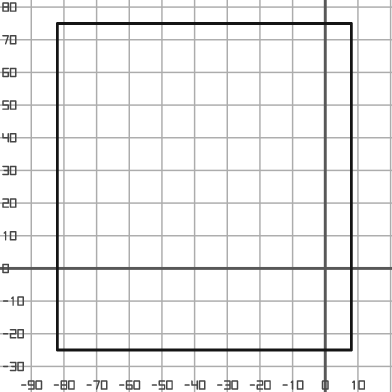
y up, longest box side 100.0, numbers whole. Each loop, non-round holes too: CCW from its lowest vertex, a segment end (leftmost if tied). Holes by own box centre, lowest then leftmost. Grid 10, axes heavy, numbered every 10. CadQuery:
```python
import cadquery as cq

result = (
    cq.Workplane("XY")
    .moveTo(-82.0, -25.0)
    .lineTo(8.0, -25.0)
    .lineTo(8.0, 75.0)
    .lineTo(-82.0, 75.0)
    .close()
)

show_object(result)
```